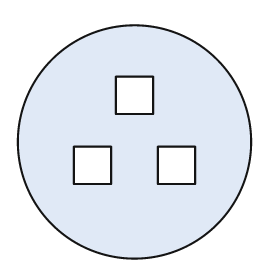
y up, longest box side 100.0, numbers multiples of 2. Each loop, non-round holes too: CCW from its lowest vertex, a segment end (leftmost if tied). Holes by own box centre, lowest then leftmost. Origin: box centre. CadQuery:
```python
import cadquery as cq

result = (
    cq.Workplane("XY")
    .moveTo(0.0, 0.0)
    .circle(50.0)
    .moveTo(-26.0, -18.0)
    .lineTo(-10.0, -18.0)
    .lineTo(-10.0, -2.0)
    .lineTo(-26.0, -2.0)
    .close()
    .moveTo(10.0, -18.0)
    .lineTo(26.0, -18.0)
    .lineTo(26.0, -2.0)
    .lineTo(10.0, -2.0)
    .close()
    .moveTo(-8.0, 12.0)
    .lineTo(8.0, 12.0)
    .lineTo(8.0, 28.0)
    .lineTo(-8.0, 28.0)
    .close()
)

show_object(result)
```